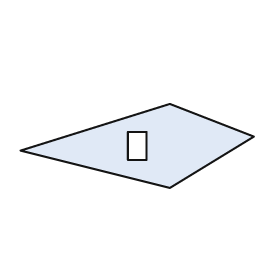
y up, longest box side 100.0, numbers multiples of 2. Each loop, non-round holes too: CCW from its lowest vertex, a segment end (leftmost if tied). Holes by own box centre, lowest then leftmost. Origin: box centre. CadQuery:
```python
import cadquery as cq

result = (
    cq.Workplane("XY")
    .moveTo(14.0, -18.0)
    .lineTo(50.0, 4.0)
    .lineTo(14.0, 18.0)
    .lineTo(-50.0, -2.0)
    .close()
    .moveTo(-4.0, -6.0)
    .lineTo(4.0, -6.0)
    .lineTo(4.0, 6.0)
    .lineTo(-4.0, 6.0)
    .close()
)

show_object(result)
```